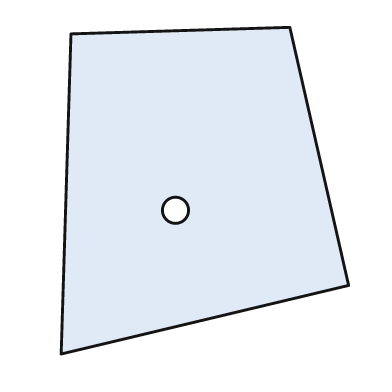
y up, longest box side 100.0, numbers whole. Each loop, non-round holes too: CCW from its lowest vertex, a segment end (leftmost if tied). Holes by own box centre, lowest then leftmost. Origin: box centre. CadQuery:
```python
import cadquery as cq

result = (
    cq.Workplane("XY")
    .moveTo(-44.0, -50.0)
    .lineTo(44.0, -29.0)
    .lineTo(26.0, 50.0)
    .lineTo(-41.0, 48.0)
    .close()
    .moveTo(-9.0, -6.0)
    .circle(4.0)
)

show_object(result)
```